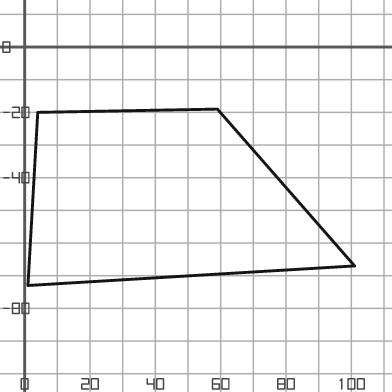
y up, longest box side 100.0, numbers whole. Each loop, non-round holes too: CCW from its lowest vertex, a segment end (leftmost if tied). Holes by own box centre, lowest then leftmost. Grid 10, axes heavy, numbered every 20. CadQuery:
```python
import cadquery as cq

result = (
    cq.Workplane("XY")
    .moveTo(1.0, -73.0)
    .lineTo(101.0, -67.0)
    .lineTo(59.0, -19.0)
    .lineTo(4.0, -20.0)
    .close()
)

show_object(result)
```